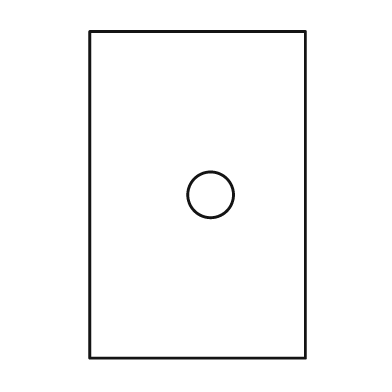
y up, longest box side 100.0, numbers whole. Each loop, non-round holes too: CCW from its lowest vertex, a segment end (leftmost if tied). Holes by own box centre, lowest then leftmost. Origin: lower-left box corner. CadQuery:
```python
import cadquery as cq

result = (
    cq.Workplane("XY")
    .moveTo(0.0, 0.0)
    .lineTo(66.0, 0.0)
    .lineTo(66.0, 100.0)
    .lineTo(0.0, 100.0)
    .close()
    .moveTo(37.0, 50.0)
    .circle(7.0)
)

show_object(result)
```